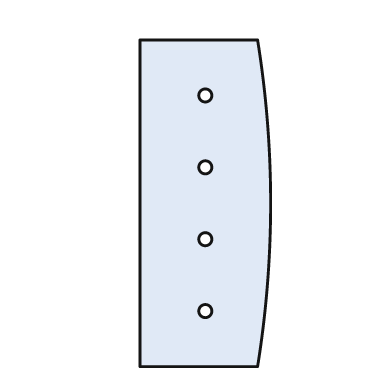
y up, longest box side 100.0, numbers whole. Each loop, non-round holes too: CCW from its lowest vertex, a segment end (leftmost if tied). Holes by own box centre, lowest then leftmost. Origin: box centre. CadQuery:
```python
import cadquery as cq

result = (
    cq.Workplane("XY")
    .moveTo(-20.0, -50.0)
    .lineTo(16.0, -50.0)
    .threePointArc((20.0, 0.0), (16.0, 50.0))
    .lineTo(-20.0, 50.0)
    .close()
    .moveTo(0.0, -33.0)
    .circle(2.0)
    .moveTo(0.0, -11.0)
    .circle(2.0)
    .moveTo(0.0, 11.0)
    .circle(2.0)
    .moveTo(0.0, 33.0)
    .circle(2.0)
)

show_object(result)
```